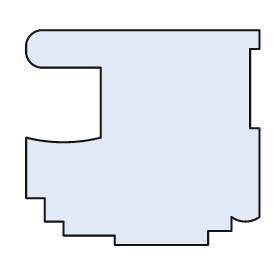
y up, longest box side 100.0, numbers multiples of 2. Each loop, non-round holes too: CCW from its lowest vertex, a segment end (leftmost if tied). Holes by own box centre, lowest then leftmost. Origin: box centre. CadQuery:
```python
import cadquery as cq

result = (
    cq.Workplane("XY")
    .moveTo(-12.0, -46.0)
    .lineTo(28.0, -46.0)
    .lineTo(28.0, -40.0)
    .lineTo(38.0, -40.0)
    .lineTo(38.0, -34.0)
    .threePointArc((44.0, -36.0), (50.0, -34.0))
    .lineTo(50.0, 4.0)
    .lineTo(46.0, 4.0)
    .lineTo(46.0, 38.0)
    .lineTo(50.0, 38.0)
    .lineTo(50.0, 46.0)
    .lineTo(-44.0, 46.0)
    .threePointArc((-48.0, 44.0), (-50.0, 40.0))
    .lineTo(-50.0, 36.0)
    .threePointArc((-48.0, 32.0), (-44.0, 30.0))
    .lineTo(-18.0, 30.0)
    .lineTo(-18.0, 0.0)
    .threePointArc((-34.0, -2.0), (-50.0, 0.0))
    .lineTo(-50.0, -26.0)
    .lineTo(-42.0, -26.0)
    .lineTo(-42.0, -36.0)
    .lineTo(-34.0, -36.0)
    .lineTo(-34.0, -42.0)
    .lineTo(-12.0, -42.0)
    .close()
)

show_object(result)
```